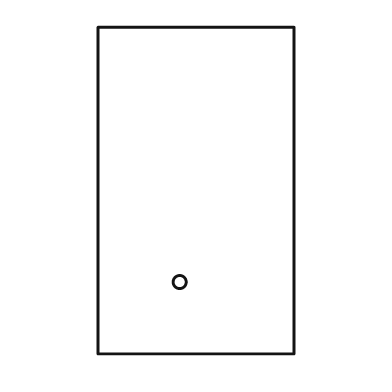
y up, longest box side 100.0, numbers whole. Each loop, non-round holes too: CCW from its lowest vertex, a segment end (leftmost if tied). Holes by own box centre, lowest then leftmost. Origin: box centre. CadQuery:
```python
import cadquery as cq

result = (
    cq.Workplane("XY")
    .moveTo(-30.0, -50.0)
    .lineTo(30.0, -50.0)
    .lineTo(30.0, 50.0)
    .lineTo(-30.0, 50.0)
    .close()
    .moveTo(-5.0, -28.0)
    .circle(2.0)
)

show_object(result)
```